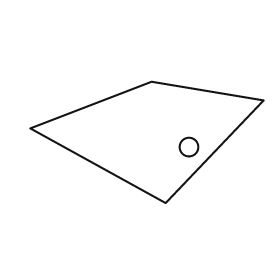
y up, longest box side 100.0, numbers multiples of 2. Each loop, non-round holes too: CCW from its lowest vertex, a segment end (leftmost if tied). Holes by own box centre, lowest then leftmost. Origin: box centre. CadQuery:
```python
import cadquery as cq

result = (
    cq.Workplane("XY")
    .moveTo(8.0, -26.0)
    .lineTo(50.0, 18.0)
    .lineTo(2.0, 26.0)
    .lineTo(-50.0, 6.0)
    .close()
    .moveTo(18.0, -2.0)
    .circle(4.0)
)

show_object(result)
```